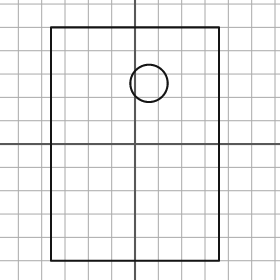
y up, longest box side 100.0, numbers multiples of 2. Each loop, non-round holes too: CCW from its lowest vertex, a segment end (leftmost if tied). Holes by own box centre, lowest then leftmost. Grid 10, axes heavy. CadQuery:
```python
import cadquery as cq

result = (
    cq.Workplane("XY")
    .moveTo(-36.0, -50.0)
    .lineTo(36.0, -50.0)
    .lineTo(36.0, 50.0)
    .lineTo(-36.0, 50.0)
    .close()
    .moveTo(6.0, 26.0)
    .circle(8.0)
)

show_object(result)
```